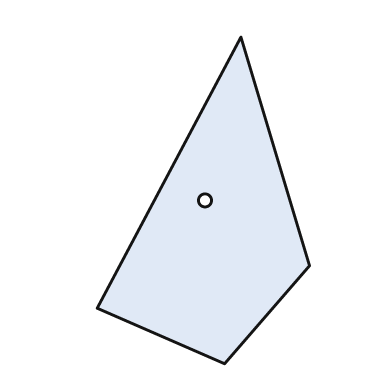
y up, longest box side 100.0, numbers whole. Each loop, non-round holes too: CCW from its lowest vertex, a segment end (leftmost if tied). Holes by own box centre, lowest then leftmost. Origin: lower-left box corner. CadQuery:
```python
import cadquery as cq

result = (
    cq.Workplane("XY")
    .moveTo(39.0, 0.0)
    .lineTo(65.0, 30.0)
    .lineTo(44.0, 100.0)
    .lineTo(0.0, 17.0)
    .close()
    .moveTo(33.0, 50.0)
    .circle(2.0)
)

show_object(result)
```